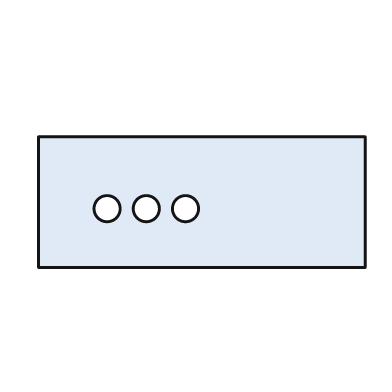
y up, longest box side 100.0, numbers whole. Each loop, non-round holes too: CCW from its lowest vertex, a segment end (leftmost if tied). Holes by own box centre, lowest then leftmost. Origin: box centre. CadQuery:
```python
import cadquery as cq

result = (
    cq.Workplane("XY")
    .moveTo(-50.0, -20.0)
    .lineTo(50.0, -20.0)
    .lineTo(50.0, 20.0)
    .lineTo(-50.0, 20.0)
    .close()
    .moveTo(-29.0, -2.0)
    .circle(4.0)
    .moveTo(-17.0, -2.0)
    .circle(4.0)
    .moveTo(-5.0, -2.0)
    .circle(4.0)
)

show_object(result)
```